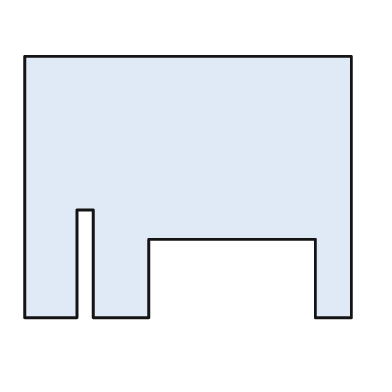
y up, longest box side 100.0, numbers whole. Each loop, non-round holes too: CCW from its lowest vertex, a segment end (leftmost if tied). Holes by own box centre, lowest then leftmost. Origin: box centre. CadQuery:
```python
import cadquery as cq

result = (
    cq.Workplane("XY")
    .moveTo(-50.0, -40.0)
    .lineTo(-34.0, -40.0)
    .lineTo(-34.0, -7.0)
    .lineTo(-29.0, -7.0)
    .lineTo(-29.0, -40.0)
    .lineTo(-12.0, -40.0)
    .lineTo(-12.0, -16.0)
    .lineTo(39.0, -16.0)
    .lineTo(39.0, -40.0)
    .lineTo(50.0, -40.0)
    .lineTo(50.0, 40.0)
    .lineTo(-50.0, 40.0)
    .close()
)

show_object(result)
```